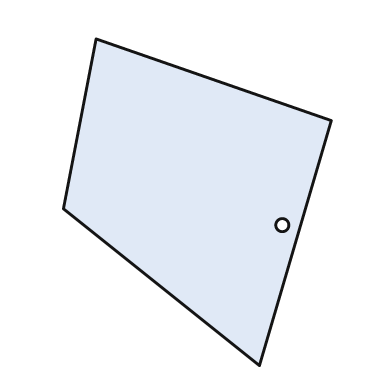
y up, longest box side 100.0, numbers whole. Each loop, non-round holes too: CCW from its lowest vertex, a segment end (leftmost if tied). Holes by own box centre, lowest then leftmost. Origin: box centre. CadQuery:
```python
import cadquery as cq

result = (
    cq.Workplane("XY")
    .moveTo(19.0, -50.0)
    .lineTo(41.0, 25.0)
    .lineTo(-31.0, 50.0)
    .lineTo(-41.0, -2.0)
    .close()
    .moveTo(26.0, -7.0)
    .circle(2.0)
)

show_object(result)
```